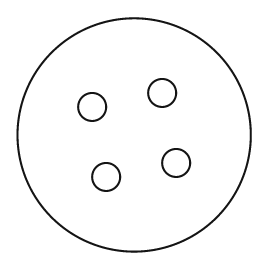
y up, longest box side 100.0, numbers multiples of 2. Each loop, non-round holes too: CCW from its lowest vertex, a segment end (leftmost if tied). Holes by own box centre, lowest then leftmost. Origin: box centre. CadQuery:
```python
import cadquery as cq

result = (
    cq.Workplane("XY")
    .moveTo(0.0, 0.0)
    .circle(50.0)
    .moveTo(-12.0, -18.0)
    .circle(6.0)
    .moveTo(18.0, -12.0)
    .circle(6.0)
    .moveTo(-18.0, 12.0)
    .circle(6.0)
    .moveTo(12.0, 18.0)
    .circle(6.0)
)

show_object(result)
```